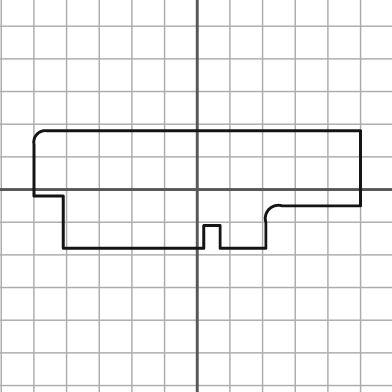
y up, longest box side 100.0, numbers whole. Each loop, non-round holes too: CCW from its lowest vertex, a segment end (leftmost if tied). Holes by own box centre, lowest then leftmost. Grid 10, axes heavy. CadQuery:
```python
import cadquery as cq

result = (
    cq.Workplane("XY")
    .moveTo(-41.0, -18.0)
    .lineTo(2.0, -18.0)
    .lineTo(2.0, -11.0)
    .lineTo(7.0, -11.0)
    .lineTo(7.0, -18.0)
    .lineTo(21.0, -18.0)
    .lineTo(21.0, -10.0)
    .threePointArc((22.0, -6.0), (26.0, -5.0))
    .lineTo(50.0, -5.0)
    .lineTo(50.0, 18.0)
    .lineTo(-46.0, 18.0)
    .threePointArc((-49.0, 17.0), (-50.0, 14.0))
    .lineTo(-50.0, -2.0)
    .lineTo(-41.0, -2.0)
    .close()
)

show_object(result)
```